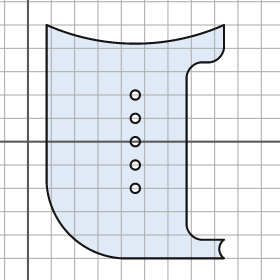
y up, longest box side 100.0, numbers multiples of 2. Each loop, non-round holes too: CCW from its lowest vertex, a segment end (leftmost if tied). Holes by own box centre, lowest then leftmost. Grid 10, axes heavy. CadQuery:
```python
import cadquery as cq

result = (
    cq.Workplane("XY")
    .moveTo(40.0, -50.0)
    .lineTo(84.0, -50.0)
    .threePointArc((82.0, -46.0), (84.0, -42.0))
    .lineTo(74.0, -42.0)
    .threePointArc((70.0, -40.0), (68.0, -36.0))
    .lineTo(68.0, 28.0)
    .threePointArc((70.0, 32.0), (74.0, 34.0))
    .lineTo(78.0, 34.0)
    .threePointArc((82.0, 36.0), (84.0, 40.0))
    .lineTo(84.0, 50.0)
    .threePointArc((46.0, 42.0), (8.0, 50.0))
    .lineTo(8.0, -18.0)
    .threePointArc((18.0, -40.0), (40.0, -50.0))
    .close()
    .moveTo(46.0, -20.0)
    .circle(2.0)
    .moveTo(46.0, -10.0)
    .circle(2.0)
    .moveTo(46.0, 0.0)
    .circle(2.0)
    .moveTo(46.0, 10.0)
    .circle(2.0)
    .moveTo(46.0, 20.0)
    .circle(2.0)
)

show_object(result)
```